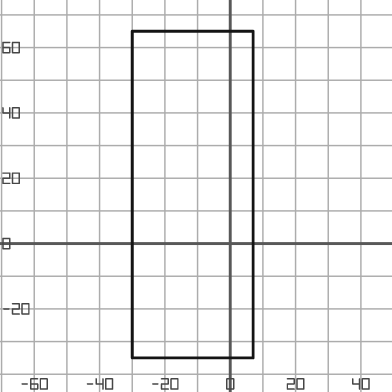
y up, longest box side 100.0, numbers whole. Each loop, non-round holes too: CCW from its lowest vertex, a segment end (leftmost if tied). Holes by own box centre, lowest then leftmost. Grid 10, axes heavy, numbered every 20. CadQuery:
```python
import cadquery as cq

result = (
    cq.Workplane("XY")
    .moveTo(-30.0, -35.0)
    .lineTo(7.0, -35.0)
    .lineTo(7.0, 65.0)
    .lineTo(-30.0, 65.0)
    .close()
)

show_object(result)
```